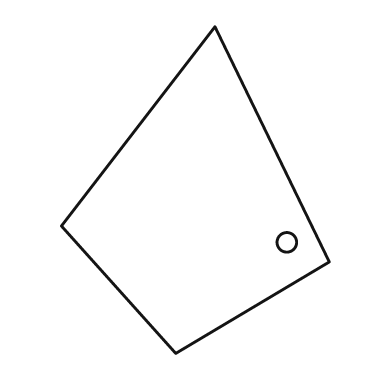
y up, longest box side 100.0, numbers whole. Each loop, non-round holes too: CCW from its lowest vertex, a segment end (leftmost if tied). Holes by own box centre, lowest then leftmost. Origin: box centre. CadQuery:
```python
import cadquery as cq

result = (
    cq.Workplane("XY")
    .moveTo(-6.0, -50.0)
    .lineTo(41.0, -22.0)
    .lineTo(6.0, 50.0)
    .lineTo(-41.0, -11.0)
    .close()
    .moveTo(28.0, -16.0)
    .circle(3.0)
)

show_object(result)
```